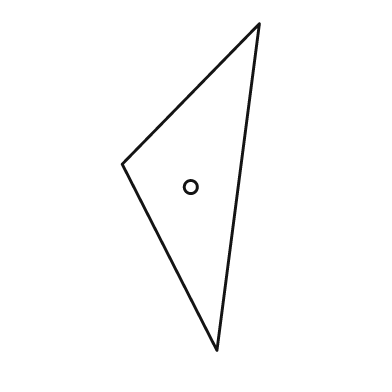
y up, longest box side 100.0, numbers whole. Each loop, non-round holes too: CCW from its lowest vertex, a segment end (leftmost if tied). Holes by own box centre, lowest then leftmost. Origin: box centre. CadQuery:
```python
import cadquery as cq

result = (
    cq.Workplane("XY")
    .moveTo(8.0, -50.0)
    .lineTo(21.0, 50.0)
    .lineTo(-21.0, 7.0)
    .close()
    .moveTo(0.0, 0.0)
    .circle(2.0)
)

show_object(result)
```